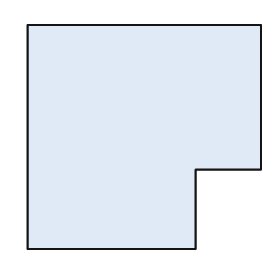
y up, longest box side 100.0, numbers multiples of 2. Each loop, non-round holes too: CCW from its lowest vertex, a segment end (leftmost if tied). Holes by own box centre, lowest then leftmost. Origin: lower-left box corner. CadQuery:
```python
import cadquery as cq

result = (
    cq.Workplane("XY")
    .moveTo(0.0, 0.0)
    .lineTo(72.0, 0.0)
    .lineTo(72.0, 34.0)
    .lineTo(100.0, 34.0)
    .lineTo(100.0, 96.0)
    .lineTo(0.0, 96.0)
    .close()
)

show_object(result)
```